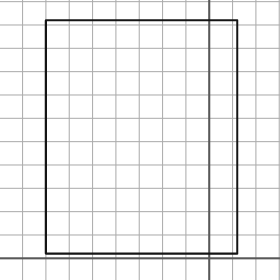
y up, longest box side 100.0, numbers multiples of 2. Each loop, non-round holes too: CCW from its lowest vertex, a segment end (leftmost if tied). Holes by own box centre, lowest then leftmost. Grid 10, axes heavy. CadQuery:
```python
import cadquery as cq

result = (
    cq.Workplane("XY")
    .moveTo(-70.0, 2.0)
    .lineTo(12.0, 2.0)
    .lineTo(12.0, 102.0)
    .lineTo(-70.0, 102.0)
    .close()
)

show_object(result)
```